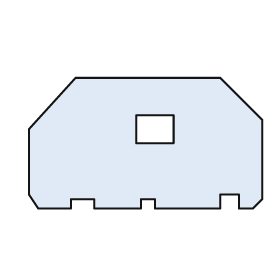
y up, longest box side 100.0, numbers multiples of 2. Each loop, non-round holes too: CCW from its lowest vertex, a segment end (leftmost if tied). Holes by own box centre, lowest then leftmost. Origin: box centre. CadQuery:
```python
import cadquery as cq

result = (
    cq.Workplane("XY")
    .moveTo(-46.0, -28.0)
    .lineTo(-32.0, -28.0)
    .lineTo(-32.0, -24.0)
    .lineTo(-22.0, -24.0)
    .lineTo(-22.0, -28.0)
    .lineTo(-2.0, -28.0)
    .lineTo(-2.0, -24.0)
    .lineTo(4.0, -24.0)
    .lineTo(4.0, -28.0)
    .lineTo(32.0, -28.0)
    .lineTo(32.0, -22.0)
    .lineTo(40.0, -22.0)
    .lineTo(40.0, -28.0)
    .lineTo(46.0, -28.0)
    .lineTo(50.0, -24.0)
    .lineTo(50.0, 10.0)
    .lineTo(32.0, 28.0)
    .lineTo(-30.0, 28.0)
    .lineTo(-50.0, 6.0)
    .lineTo(-50.0, -22.0)
    .close()
    .moveTo(-4.0, 0.0)
    .lineTo(12.0, 0.0)
    .lineTo(12.0, 12.0)
    .lineTo(-4.0, 12.0)
    .close()
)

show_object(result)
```